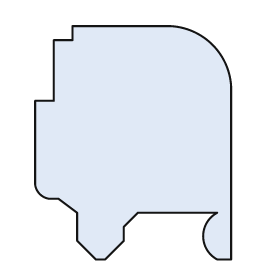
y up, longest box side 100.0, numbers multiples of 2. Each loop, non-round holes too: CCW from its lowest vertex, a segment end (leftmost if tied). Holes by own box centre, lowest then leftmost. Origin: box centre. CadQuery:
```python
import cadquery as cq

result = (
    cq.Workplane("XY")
    .moveTo(-16.0, -50.0)
    .lineTo(-12.0, -50.0)
    .lineTo(-4.0, -42.0)
    .lineTo(-4.0, -36.0)
    .lineTo(2.0, -30.0)
    .lineTo(36.0, -30.0)
    .threePointArc((30.0, -40.0), (36.0, -50.0))
    .lineTo(42.0, -50.0)
    .lineTo(42.0, 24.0)
    .threePointArc((34.0, 42.0), (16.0, 50.0))
    .lineTo(-26.0, 50.0)
    .lineTo(-26.0, 44.0)
    .lineTo(-34.0, 44.0)
    .lineTo(-34.0, 18.0)
    .lineTo(-42.0, 18.0)
    .lineTo(-42.0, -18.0)
    .threePointArc((-40.0, -22.0), (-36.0, -24.0))
    .lineTo(-32.0, -24.0)
    .lineTo(-24.0, -30.0)
    .lineTo(-24.0, -42.0)
    .close()
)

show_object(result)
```